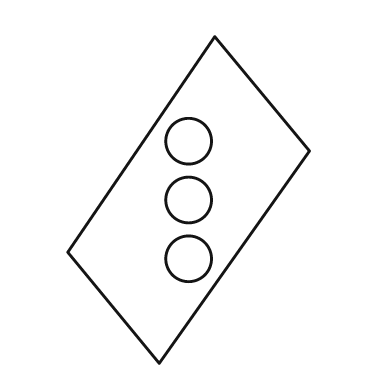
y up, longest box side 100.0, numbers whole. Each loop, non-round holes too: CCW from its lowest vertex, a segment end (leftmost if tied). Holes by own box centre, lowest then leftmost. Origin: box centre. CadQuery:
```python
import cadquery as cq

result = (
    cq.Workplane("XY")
    .moveTo(-9.0, -50.0)
    .lineTo(37.0, 15.0)
    .lineTo(8.0, 50.0)
    .lineTo(-37.0, -16.0)
    .close()
    .moveTo(0.0, -18.0)
    .circle(7.0)
    .moveTo(0.0, 0.0)
    .circle(7.0)
    .moveTo(0.0, 18.0)
    .circle(7.0)
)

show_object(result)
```